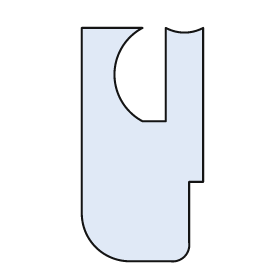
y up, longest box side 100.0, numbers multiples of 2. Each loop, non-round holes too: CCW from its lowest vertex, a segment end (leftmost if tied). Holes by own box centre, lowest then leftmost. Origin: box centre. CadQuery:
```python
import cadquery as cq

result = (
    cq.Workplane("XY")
    .moveTo(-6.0, -50.0)
    .lineTo(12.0, -50.0)
    .threePointArc((18.0, -48.0), (20.0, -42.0))
    .lineTo(20.0, -16.0)
    .lineTo(26.0, -16.0)
    .lineTo(26.0, 50.0)
    .threePointArc((18.0, 48.0), (10.0, 50.0))
    .lineTo(10.0, 10.0)
    .lineTo(0.0, 10.0)
    .threePointArc((-12.0, 30.0), (0.0, 50.0))
    .lineTo(-26.0, 50.0)
    .lineTo(-26.0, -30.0)
    .threePointArc((-20.0, -44.0), (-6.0, -50.0))
    .close()
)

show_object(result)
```